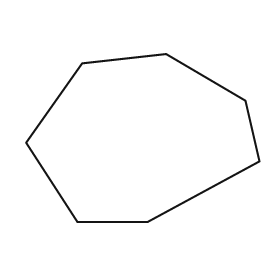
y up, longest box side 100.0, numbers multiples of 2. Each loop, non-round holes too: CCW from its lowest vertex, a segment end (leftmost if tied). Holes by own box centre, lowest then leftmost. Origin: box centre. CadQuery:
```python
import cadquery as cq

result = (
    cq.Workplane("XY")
    .moveTo(-28.0, -36.0)
    .lineTo(2.0, -36.0)
    .lineTo(50.0, -10.0)
    .lineTo(44.0, 16.0)
    .lineTo(10.0, 36.0)
    .lineTo(-26.0, 32.0)
    .lineTo(-50.0, -2.0)
    .close()
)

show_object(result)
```